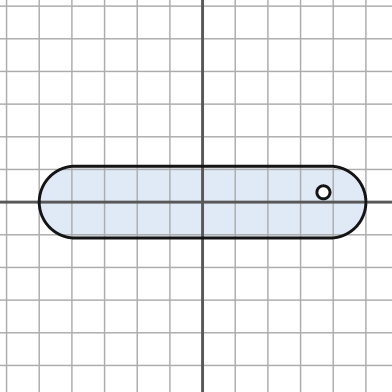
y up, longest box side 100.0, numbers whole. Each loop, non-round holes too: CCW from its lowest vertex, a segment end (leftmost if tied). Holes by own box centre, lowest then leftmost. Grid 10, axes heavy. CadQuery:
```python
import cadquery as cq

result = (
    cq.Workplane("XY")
    .moveTo(-39.0, -11.0)
    .lineTo(39.0, -11.0)
    .threePointArc((50.0, 0.0), (39.0, 11.0))
    .lineTo(-39.0, 11.0)
    .threePointArc((-50.0, 0.0), (-39.0, -11.0))
    .close()
    .moveTo(37.0, 3.0)
    .circle(2.0)
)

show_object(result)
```